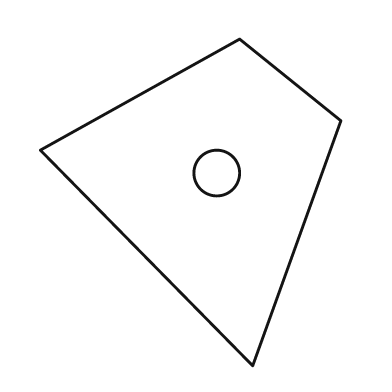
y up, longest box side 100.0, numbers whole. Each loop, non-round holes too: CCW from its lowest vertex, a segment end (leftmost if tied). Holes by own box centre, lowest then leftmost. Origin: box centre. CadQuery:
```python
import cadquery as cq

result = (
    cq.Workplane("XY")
    .moveTo(19.0, -50.0)
    .lineTo(46.0, 25.0)
    .lineTo(15.0, 50.0)
    .lineTo(-46.0, 16.0)
    .close()
    .moveTo(8.0, 9.0)
    .circle(7.0)
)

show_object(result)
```